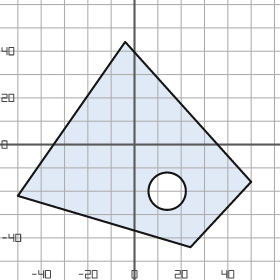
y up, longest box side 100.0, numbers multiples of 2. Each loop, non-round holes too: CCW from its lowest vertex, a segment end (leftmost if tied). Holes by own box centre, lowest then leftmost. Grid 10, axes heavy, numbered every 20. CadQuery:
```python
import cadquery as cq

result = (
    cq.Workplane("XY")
    .moveTo(24.0, -44.0)
    .lineTo(50.0, -16.0)
    .lineTo(-4.0, 44.0)
    .lineTo(-50.0, -22.0)
    .close()
    .moveTo(14.0, -20.0)
    .circle(8.0)
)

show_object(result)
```